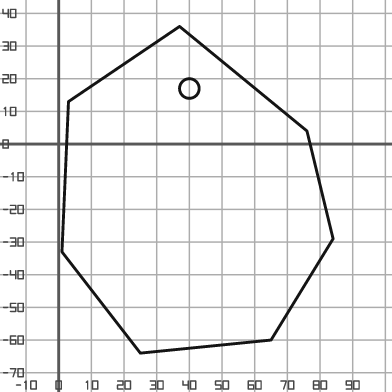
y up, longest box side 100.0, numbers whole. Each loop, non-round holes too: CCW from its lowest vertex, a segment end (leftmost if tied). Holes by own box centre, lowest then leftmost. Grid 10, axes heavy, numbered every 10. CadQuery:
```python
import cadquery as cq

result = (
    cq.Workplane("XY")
    .moveTo(25.0, -64.0)
    .lineTo(65.0, -60.0)
    .lineTo(84.0, -29.0)
    .lineTo(76.0, 4.0)
    .lineTo(37.0, 36.0)
    .lineTo(3.0, 13.0)
    .lineTo(1.0, -33.0)
    .close()
    .moveTo(40.0, 17.0)
    .circle(3.0)
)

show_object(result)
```